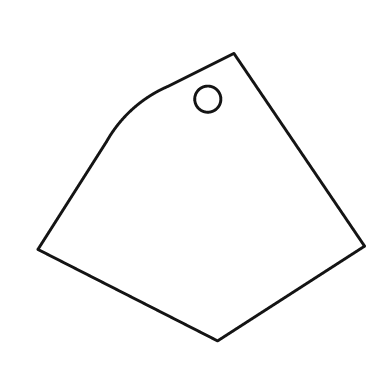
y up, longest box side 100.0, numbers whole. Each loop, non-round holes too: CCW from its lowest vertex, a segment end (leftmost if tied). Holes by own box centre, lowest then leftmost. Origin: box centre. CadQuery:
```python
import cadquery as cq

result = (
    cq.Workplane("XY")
    .moveTo(5.0, -44.0)
    .lineTo(50.0, -15.0)
    .lineTo(10.0, 44.0)
    .lineTo(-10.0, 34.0)
    .threePointArc((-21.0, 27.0), (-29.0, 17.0))
    .lineTo(-50.0, -16.0)
    .close()
    .moveTo(2.0, 30.0)
    .circle(4.0)
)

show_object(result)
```